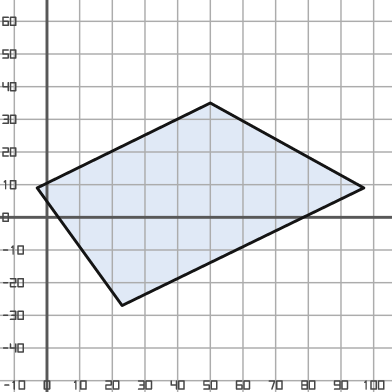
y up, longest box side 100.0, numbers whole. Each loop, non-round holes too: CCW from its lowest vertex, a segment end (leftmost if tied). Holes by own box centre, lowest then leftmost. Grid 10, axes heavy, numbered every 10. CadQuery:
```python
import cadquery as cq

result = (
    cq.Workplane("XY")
    .moveTo(23.0, -27.0)
    .lineTo(97.0, 9.0)
    .lineTo(50.0, 35.0)
    .lineTo(-3.0, 9.0)
    .close()
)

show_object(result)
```